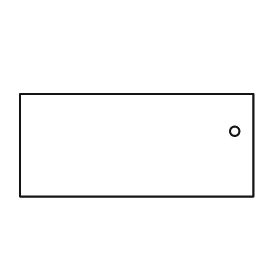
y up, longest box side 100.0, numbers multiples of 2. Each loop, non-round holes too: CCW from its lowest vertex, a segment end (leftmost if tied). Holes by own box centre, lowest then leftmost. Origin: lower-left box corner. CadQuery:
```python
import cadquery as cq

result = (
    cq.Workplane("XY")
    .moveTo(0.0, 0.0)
    .lineTo(100.0, 0.0)
    .lineTo(100.0, 44.0)
    .lineTo(0.0, 44.0)
    .close()
    .moveTo(92.0, 28.0)
    .circle(2.0)
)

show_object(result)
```